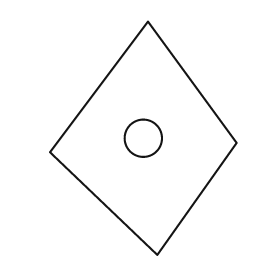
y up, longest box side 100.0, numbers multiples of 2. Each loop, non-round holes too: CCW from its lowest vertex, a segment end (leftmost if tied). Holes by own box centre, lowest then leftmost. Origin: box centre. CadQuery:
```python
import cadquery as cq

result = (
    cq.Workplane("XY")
    .moveTo(6.0, -50.0)
    .lineTo(40.0, -2.0)
    .lineTo(2.0, 50.0)
    .lineTo(-40.0, -6.0)
    .close()
    .moveTo(0.0, 0.0)
    .circle(8.0)
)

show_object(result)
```